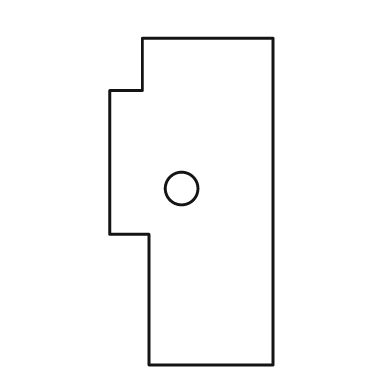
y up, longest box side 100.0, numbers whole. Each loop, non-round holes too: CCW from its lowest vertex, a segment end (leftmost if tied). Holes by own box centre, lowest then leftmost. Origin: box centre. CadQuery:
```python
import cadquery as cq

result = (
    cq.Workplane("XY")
    .moveTo(-13.0, -50.0)
    .lineTo(25.0, -50.0)
    .lineTo(25.0, 50.0)
    .lineTo(-15.0, 50.0)
    .lineTo(-15.0, 34.0)
    .lineTo(-25.0, 34.0)
    .lineTo(-25.0, -10.0)
    .lineTo(-13.0, -10.0)
    .close()
    .moveTo(-3.0, 4.0)
    .circle(5.0)
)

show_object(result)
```